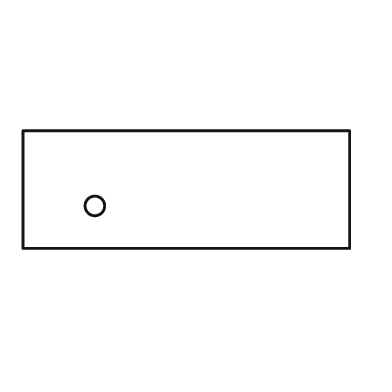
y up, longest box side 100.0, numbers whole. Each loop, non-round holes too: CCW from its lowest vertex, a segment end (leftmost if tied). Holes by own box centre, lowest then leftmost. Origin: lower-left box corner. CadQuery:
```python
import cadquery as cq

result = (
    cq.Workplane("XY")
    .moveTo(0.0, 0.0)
    .lineTo(100.0, 0.0)
    .lineTo(100.0, 36.0)
    .lineTo(0.0, 36.0)
    .close()
    .moveTo(22.0, 13.0)
    .circle(3.0)
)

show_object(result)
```